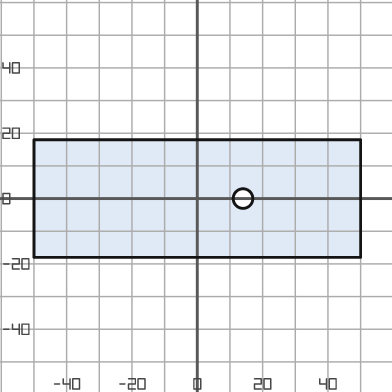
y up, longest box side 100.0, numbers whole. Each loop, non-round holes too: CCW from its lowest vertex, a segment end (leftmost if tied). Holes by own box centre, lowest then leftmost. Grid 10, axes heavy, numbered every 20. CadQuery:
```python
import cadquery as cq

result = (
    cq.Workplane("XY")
    .moveTo(-50.0, -18.0)
    .lineTo(50.0, -18.0)
    .lineTo(50.0, 18.0)
    .lineTo(-50.0, 18.0)
    .close()
    .moveTo(14.0, 0.0)
    .circle(3.0)
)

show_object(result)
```